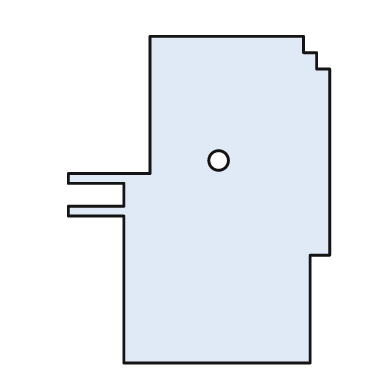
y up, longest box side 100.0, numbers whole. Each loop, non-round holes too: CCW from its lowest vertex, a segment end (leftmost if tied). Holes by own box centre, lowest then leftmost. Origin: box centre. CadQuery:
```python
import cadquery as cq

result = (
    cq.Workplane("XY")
    .moveTo(-23.0, -50.0)
    .lineTo(34.0, -50.0)
    .lineTo(34.0, -17.0)
    .lineTo(40.0, -17.0)
    .lineTo(40.0, 40.0)
    .lineTo(36.0, 40.0)
    .lineTo(36.0, 45.0)
    .lineTo(32.0, 45.0)
    .lineTo(32.0, 50.0)
    .lineTo(-15.0, 50.0)
    .lineTo(-15.0, 8.0)
    .lineTo(-40.0, 8.0)
    .lineTo(-40.0, 5.0)
    .lineTo(-23.0, 5.0)
    .lineTo(-23.0, -2.0)
    .lineTo(-40.0, -2.0)
    .lineTo(-40.0, -5.0)
    .lineTo(-23.0, -5.0)
    .close()
    .moveTo(6.0, 12.0)
    .circle(3.0)
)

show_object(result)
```